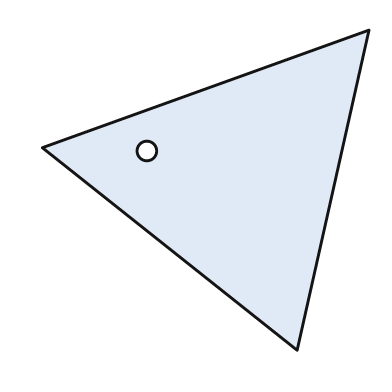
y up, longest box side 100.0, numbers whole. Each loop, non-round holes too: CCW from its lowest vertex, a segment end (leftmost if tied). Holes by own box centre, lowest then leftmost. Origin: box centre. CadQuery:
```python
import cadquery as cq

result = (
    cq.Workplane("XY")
    .moveTo(28.0, -49.0)
    .lineTo(50.0, 49.0)
    .lineTo(-50.0, 13.0)
    .close()
    .moveTo(-18.0, 12.0)
    .circle(3.0)
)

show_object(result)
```